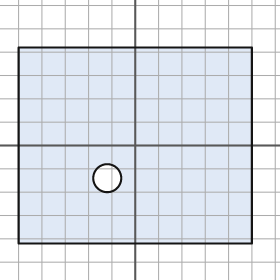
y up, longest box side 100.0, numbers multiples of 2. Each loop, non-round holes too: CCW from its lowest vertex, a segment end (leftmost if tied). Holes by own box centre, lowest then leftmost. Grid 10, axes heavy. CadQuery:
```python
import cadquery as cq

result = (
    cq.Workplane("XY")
    .moveTo(-50.0, -42.0)
    .lineTo(50.0, -42.0)
    .lineTo(50.0, 42.0)
    .lineTo(-50.0, 42.0)
    .close()
    .moveTo(-12.0, -14.0)
    .circle(6.0)
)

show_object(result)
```